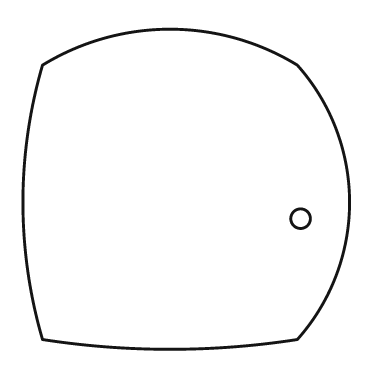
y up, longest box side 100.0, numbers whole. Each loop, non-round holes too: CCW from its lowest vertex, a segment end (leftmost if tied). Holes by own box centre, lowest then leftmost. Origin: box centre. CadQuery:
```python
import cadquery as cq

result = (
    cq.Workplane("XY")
    .moveTo(-44.0, -46.0)
    .threePointArc((-5.0, -49.0), (34.0, -46.0))
    .threePointArc((50.0, -4.0), (34.0, 38.0))
    .threePointArc((-5.0, 49.0), (-44.0, 38.0))
    .threePointArc((-50.0, -4.0), (-44.0, -46.0))
    .close()
    .moveTo(35.0, -9.0)
    .circle(3.0)
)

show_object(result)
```